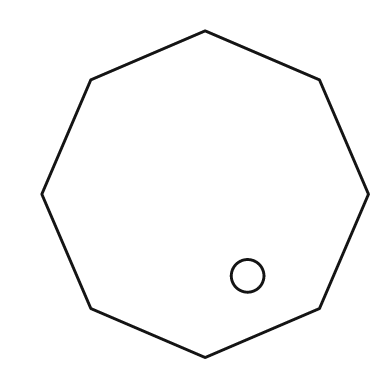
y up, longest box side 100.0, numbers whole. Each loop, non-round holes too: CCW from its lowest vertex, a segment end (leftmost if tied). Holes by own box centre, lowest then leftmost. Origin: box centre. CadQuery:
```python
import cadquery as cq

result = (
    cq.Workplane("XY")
    .moveTo(0.0, -50.0)
    .lineTo(35.0, -35.0)
    .lineTo(50.0, 0.0)
    .lineTo(35.0, 35.0)
    .lineTo(0.0, 50.0)
    .lineTo(-35.0, 35.0)
    .lineTo(-50.0, 0.0)
    .lineTo(-35.0, -35.0)
    .close()
    .moveTo(13.0, -25.0)
    .circle(5.0)
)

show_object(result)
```